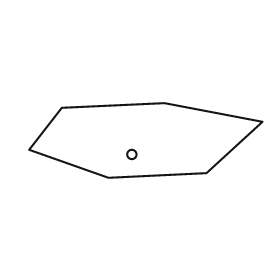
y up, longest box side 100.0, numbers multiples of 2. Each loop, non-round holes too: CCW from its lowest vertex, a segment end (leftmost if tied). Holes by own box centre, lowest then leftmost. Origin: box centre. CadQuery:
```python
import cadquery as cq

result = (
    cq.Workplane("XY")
    .moveTo(-16.0, -16.0)
    .lineTo(26.0, -14.0)
    .lineTo(50.0, 8.0)
    .lineTo(8.0, 16.0)
    .lineTo(-36.0, 14.0)
    .lineTo(-50.0, -4.0)
    .close()
    .moveTo(-6.0, -6.0)
    .circle(2.0)
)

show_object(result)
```